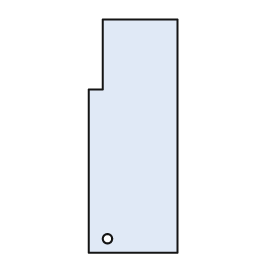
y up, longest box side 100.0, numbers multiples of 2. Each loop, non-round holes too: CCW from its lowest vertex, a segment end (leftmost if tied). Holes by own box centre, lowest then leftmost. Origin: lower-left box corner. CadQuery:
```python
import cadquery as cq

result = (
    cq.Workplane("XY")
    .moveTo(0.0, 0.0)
    .lineTo(38.0, 0.0)
    .lineTo(38.0, 100.0)
    .lineTo(6.0, 100.0)
    .lineTo(6.0, 70.0)
    .lineTo(0.0, 70.0)
    .close()
    .moveTo(8.0, 6.0)
    .circle(2.0)
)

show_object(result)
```